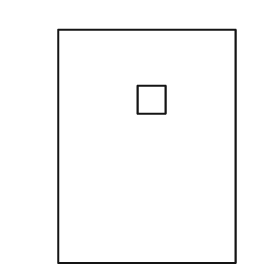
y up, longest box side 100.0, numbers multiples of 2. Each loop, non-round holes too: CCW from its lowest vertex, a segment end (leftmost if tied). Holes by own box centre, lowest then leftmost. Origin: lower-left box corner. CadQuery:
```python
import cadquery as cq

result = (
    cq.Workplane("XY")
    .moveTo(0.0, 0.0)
    .lineTo(76.0, 0.0)
    .lineTo(76.0, 100.0)
    .lineTo(0.0, 100.0)
    .close()
    .moveTo(34.0, 64.0)
    .lineTo(46.0, 64.0)
    .lineTo(46.0, 76.0)
    .lineTo(34.0, 76.0)
    .close()
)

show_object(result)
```